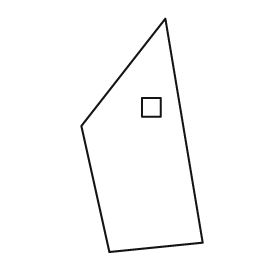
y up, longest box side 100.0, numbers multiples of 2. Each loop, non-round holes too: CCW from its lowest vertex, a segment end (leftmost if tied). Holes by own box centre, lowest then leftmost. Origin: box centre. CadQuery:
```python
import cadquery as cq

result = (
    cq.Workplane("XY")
    .moveTo(-14.0, -50.0)
    .lineTo(26.0, -46.0)
    .lineTo(10.0, 50.0)
    .lineTo(-26.0, 4.0)
    .close()
    .moveTo(0.0, 8.0)
    .lineTo(8.0, 8.0)
    .lineTo(8.0, 16.0)
    .lineTo(0.0, 16.0)
    .close()
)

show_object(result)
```